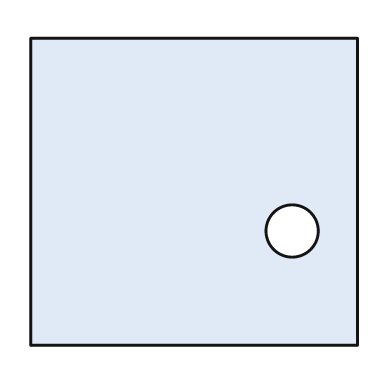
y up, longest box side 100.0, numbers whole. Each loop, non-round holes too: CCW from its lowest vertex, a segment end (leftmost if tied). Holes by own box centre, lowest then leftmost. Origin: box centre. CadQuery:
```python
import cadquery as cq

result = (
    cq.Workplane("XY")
    .moveTo(-50.0, -47.0)
    .lineTo(50.0, -47.0)
    .lineTo(50.0, 47.0)
    .lineTo(-50.0, 47.0)
    .close()
    .moveTo(30.0, -12.0)
    .circle(8.0)
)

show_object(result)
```